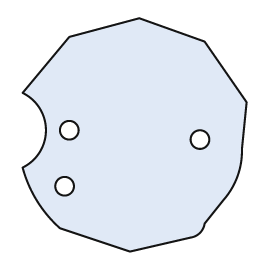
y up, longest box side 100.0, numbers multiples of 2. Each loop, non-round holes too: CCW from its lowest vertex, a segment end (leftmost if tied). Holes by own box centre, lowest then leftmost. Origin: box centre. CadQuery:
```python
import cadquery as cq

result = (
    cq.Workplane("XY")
    .moveTo(-2.0, -50.0)
    .lineTo(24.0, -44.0)
    .threePointArc((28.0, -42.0), (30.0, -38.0))
    .lineTo(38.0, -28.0)
    .threePointArc((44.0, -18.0), (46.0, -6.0))
    .lineTo(48.0, 14.0)
    .lineTo(30.0, 40.0)
    .lineTo(2.0, 50.0)
    .lineTo(-28.0, 42.0)
    .lineTo(-48.0, 18.0)
    .threePointArc((-38.0, 2.0), (-48.0, -14.0))
    .threePointArc((-42.0, -28.0), (-32.0, -40.0))
    .close()
    .moveTo(-30.0, -22.0)
    .circle(4.0)
    .moveTo(28.0, -2.0)
    .circle(4.0)
    .moveTo(-28.0, 2.0)
    .circle(4.0)
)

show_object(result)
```